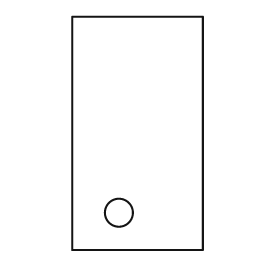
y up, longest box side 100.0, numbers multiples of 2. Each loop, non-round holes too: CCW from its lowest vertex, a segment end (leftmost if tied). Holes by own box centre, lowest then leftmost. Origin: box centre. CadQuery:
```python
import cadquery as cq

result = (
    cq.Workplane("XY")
    .moveTo(-28.0, -50.0)
    .lineTo(28.0, -50.0)
    .lineTo(28.0, 50.0)
    .lineTo(-28.0, 50.0)
    .close()
    .moveTo(-8.0, -34.0)
    .circle(6.0)
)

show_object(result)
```